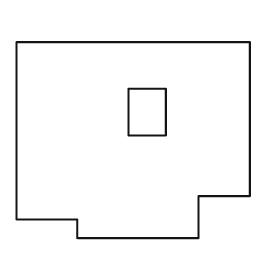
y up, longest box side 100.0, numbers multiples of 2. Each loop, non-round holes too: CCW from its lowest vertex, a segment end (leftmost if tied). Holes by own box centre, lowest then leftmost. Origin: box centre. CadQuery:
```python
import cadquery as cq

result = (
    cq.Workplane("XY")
    .moveTo(-24.0, -42.0)
    .lineTo(28.0, -42.0)
    .lineTo(28.0, -24.0)
    .lineTo(50.0, -24.0)
    .lineTo(50.0, 42.0)
    .lineTo(-50.0, 42.0)
    .lineTo(-50.0, -34.0)
    .lineTo(-24.0, -34.0)
    .close()
    .moveTo(-2.0, 2.0)
    .lineTo(14.0, 2.0)
    .lineTo(14.0, 22.0)
    .lineTo(-2.0, 22.0)
    .close()
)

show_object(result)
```